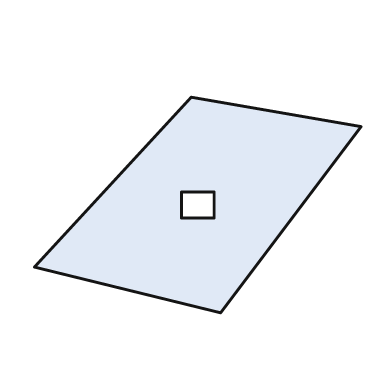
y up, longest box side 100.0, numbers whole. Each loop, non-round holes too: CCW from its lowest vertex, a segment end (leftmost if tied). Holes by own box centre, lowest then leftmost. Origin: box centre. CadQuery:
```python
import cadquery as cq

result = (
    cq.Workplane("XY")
    .moveTo(7.0, -33.0)
    .lineTo(50.0, 24.0)
    .lineTo(-2.0, 33.0)
    .lineTo(-50.0, -19.0)
    .close()
    .moveTo(-5.0, -4.0)
    .lineTo(5.0, -4.0)
    .lineTo(5.0, 4.0)
    .lineTo(-5.0, 4.0)
    .close()
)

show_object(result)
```